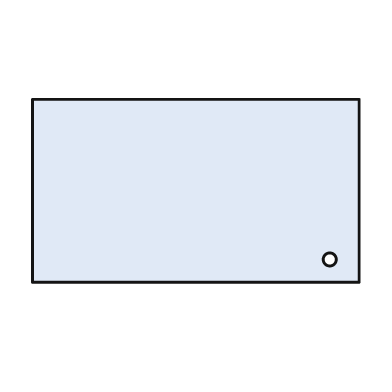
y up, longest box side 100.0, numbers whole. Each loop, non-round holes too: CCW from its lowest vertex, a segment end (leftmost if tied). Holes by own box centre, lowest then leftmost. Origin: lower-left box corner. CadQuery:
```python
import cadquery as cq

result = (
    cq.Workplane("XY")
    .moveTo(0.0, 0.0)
    .lineTo(100.0, 0.0)
    .lineTo(100.0, 56.0)
    .lineTo(0.0, 56.0)
    .close()
    .moveTo(91.0, 7.0)
    .circle(2.0)
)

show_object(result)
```